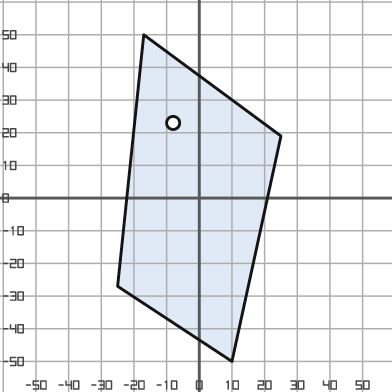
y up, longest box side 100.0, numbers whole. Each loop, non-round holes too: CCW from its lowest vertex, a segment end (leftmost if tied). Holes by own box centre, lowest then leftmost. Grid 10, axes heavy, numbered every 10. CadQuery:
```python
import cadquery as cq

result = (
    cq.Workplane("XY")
    .moveTo(10.0, -50.0)
    .lineTo(25.0, 19.0)
    .lineTo(-17.0, 50.0)
    .lineTo(-25.0, -27.0)
    .close()
    .moveTo(-8.0, 23.0)
    .circle(2.0)
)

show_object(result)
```